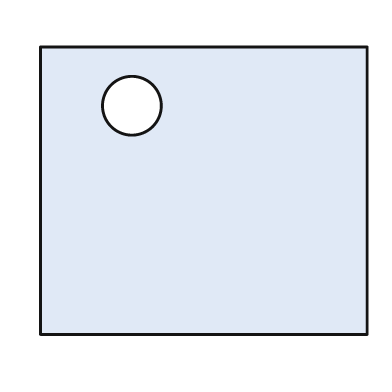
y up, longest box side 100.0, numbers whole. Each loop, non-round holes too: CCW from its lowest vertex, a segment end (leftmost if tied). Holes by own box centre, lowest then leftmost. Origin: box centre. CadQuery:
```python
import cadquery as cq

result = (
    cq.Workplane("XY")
    .moveTo(-50.0, -44.0)
    .lineTo(50.0, -44.0)
    .lineTo(50.0, 44.0)
    .lineTo(-50.0, 44.0)
    .close()
    .moveTo(-22.0, 26.0)
    .circle(9.0)
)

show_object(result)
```